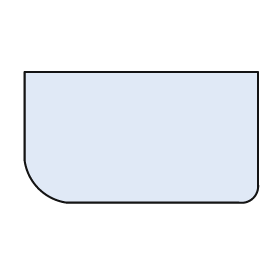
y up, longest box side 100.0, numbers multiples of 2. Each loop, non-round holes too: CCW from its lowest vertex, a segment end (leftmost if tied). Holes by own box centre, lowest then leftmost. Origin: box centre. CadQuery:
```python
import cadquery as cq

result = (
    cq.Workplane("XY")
    .moveTo(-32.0, -28.0)
    .lineTo(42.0, -28.0)
    .threePointArc((48.0, -26.0), (50.0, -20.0))
    .lineTo(50.0, 28.0)
    .lineTo(-50.0, 28.0)
    .lineTo(-50.0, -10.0)
    .threePointArc((-44.0, -22.0), (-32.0, -28.0))
    .close()
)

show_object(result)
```